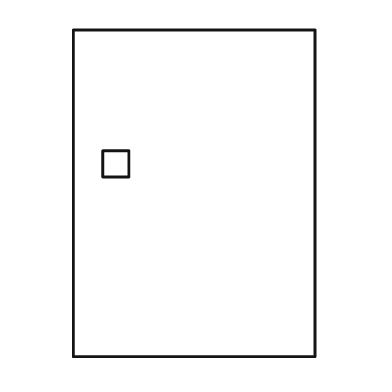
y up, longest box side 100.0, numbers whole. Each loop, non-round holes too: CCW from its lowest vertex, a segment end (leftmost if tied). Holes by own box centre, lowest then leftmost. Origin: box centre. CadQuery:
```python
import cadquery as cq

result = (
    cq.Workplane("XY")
    .moveTo(-37.0, -50.0)
    .lineTo(37.0, -50.0)
    .lineTo(37.0, 50.0)
    .lineTo(-37.0, 50.0)
    .close()
    .moveTo(-28.0, 5.0)
    .lineTo(-20.0, 5.0)
    .lineTo(-20.0, 13.0)
    .lineTo(-28.0, 13.0)
    .close()
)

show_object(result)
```